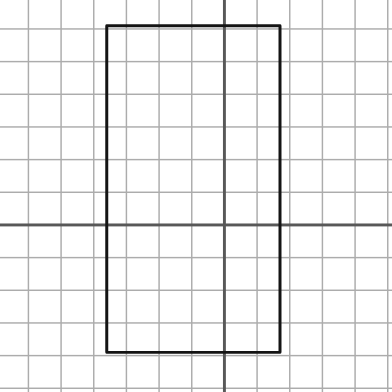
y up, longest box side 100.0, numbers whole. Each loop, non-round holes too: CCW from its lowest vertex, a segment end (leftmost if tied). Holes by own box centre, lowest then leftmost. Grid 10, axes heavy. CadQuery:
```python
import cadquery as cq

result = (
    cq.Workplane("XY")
    .moveTo(-36.0, -39.0)
    .lineTo(17.0, -39.0)
    .lineTo(17.0, 61.0)
    .lineTo(-36.0, 61.0)
    .close()
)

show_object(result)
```